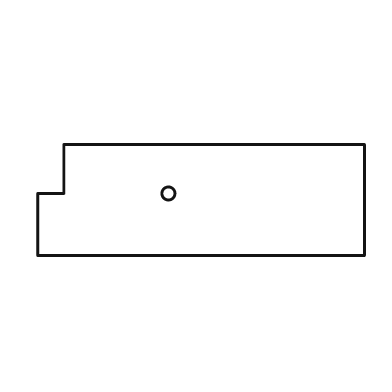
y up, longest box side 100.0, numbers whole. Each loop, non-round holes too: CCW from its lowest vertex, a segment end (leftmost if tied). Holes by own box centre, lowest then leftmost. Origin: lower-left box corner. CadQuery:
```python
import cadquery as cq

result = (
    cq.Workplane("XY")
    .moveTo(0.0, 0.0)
    .lineTo(100.0, 0.0)
    .lineTo(100.0, 34.0)
    .lineTo(8.0, 34.0)
    .lineTo(8.0, 19.0)
    .lineTo(0.0, 19.0)
    .close()
    .moveTo(40.0, 19.0)
    .circle(2.0)
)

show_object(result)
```